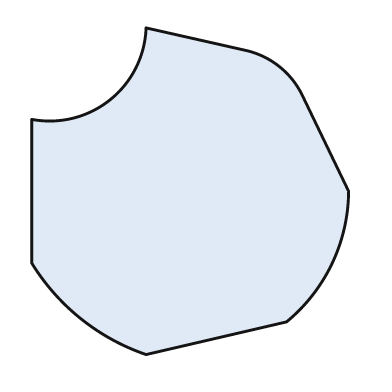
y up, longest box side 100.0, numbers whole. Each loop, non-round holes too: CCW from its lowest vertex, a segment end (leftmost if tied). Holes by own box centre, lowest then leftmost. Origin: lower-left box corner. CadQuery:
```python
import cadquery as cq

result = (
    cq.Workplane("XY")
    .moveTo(35.0, 0.0)
    .lineTo(78.0, 10.0)
    .threePointArc((92.0, 28.0), (97.0, 50.0))
    .lineTo(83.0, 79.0)
    .threePointArc((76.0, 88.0), (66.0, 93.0))
    .lineTo(35.0, 100.0)
    .threePointArc((24.0, 78.0), (0.0, 72.0))
    .lineTo(0.0, 28.0)
    .threePointArc((15.0, 11.0), (35.0, 0.0))
    .close()
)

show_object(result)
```